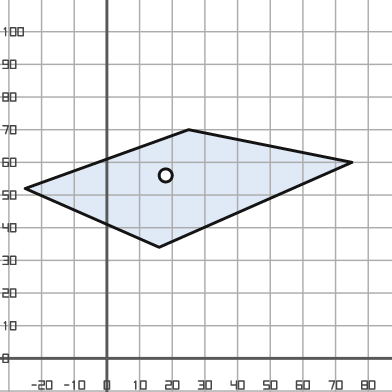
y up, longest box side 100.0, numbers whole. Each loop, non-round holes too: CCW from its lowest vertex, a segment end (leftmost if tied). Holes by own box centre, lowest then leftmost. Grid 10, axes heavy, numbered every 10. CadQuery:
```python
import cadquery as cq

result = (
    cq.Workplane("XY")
    .moveTo(16.0, 34.0)
    .lineTo(75.0, 60.0)
    .lineTo(25.0, 70.0)
    .lineTo(-25.0, 52.0)
    .close()
    .moveTo(18.0, 56.0)
    .circle(2.0)
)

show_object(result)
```